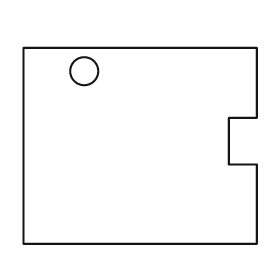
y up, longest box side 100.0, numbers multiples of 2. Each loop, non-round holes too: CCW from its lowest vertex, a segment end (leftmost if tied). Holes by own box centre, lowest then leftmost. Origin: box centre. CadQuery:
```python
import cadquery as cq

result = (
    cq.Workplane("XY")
    .moveTo(-50.0, -42.0)
    .lineTo(50.0, -42.0)
    .lineTo(50.0, -8.0)
    .lineTo(38.0, -8.0)
    .lineTo(38.0, 12.0)
    .lineTo(50.0, 12.0)
    .lineTo(50.0, 42.0)
    .lineTo(-50.0, 42.0)
    .close()
    .moveTo(-24.0, 32.0)
    .circle(6.0)
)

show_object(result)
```